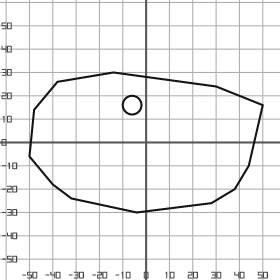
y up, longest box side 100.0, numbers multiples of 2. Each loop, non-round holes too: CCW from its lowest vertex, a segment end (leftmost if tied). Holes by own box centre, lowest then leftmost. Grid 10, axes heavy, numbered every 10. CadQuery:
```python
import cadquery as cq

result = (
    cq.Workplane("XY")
    .moveTo(-4.0, -30.0)
    .lineTo(28.0, -26.0)
    .lineTo(38.0, -20.0)
    .lineTo(44.0, -10.0)
    .lineTo(50.0, 16.0)
    .lineTo(30.0, 24.0)
    .lineTo(-14.0, 30.0)
    .lineTo(-38.0, 26.0)
    .lineTo(-48.0, 14.0)
    .lineTo(-50.0, -6.0)
    .lineTo(-40.0, -18.0)
    .lineTo(-32.0, -24.0)
    .close()
    .moveTo(-6.0, 16.0)
    .circle(4.0)
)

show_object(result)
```